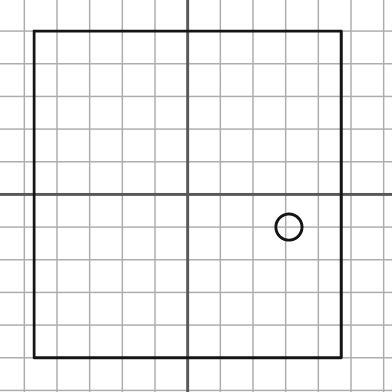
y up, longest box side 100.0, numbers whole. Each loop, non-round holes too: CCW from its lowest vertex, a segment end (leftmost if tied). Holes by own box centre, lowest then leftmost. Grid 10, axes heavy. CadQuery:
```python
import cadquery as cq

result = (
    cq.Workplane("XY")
    .moveTo(-47.0, -50.0)
    .lineTo(47.0, -50.0)
    .lineTo(47.0, 50.0)
    .lineTo(-47.0, 50.0)
    .close()
    .moveTo(31.0, -10.0)
    .circle(4.0)
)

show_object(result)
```